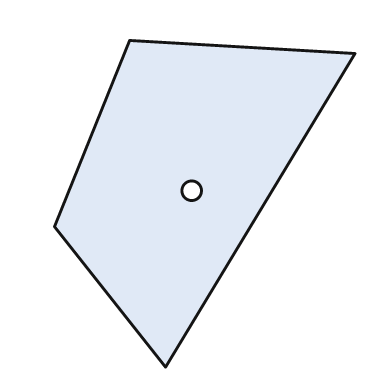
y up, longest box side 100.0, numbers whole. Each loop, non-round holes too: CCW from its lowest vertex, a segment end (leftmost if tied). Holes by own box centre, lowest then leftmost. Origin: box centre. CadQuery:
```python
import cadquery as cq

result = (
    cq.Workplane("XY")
    .moveTo(-12.0, -50.0)
    .lineTo(46.0, 46.0)
    .lineTo(-23.0, 50.0)
    .lineTo(-46.0, -7.0)
    .close()
    .moveTo(-4.0, 4.0)
    .circle(3.0)
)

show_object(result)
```